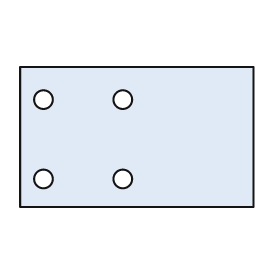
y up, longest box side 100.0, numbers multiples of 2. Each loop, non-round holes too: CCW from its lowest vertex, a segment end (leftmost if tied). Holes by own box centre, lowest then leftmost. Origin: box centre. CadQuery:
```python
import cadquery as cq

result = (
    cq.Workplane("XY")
    .moveTo(-50.0, -30.0)
    .lineTo(50.0, -30.0)
    .lineTo(50.0, 30.0)
    .lineTo(-50.0, 30.0)
    .close()
    .moveTo(-40.0, -18.0)
    .circle(4.0)
    .moveTo(-6.0, -18.0)
    .circle(4.0)
    .moveTo(-40.0, 16.0)
    .circle(4.0)
    .moveTo(-6.0, 16.0)
    .circle(4.0)
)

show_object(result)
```